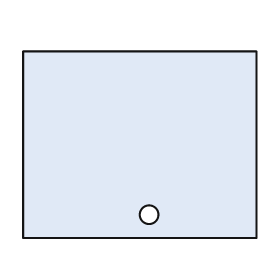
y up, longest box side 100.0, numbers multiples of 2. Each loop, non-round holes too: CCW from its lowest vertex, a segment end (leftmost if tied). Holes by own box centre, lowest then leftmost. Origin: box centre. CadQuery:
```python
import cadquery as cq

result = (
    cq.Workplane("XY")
    .moveTo(-50.0, -40.0)
    .lineTo(50.0, -40.0)
    .lineTo(50.0, 40.0)
    .lineTo(-50.0, 40.0)
    .close()
    .moveTo(4.0, -30.0)
    .circle(4.0)
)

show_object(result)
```